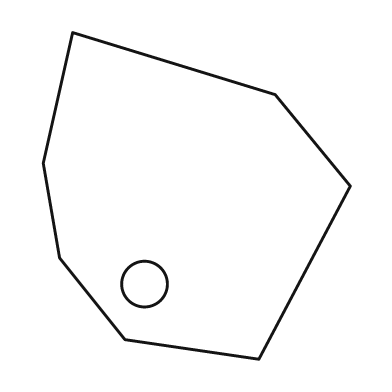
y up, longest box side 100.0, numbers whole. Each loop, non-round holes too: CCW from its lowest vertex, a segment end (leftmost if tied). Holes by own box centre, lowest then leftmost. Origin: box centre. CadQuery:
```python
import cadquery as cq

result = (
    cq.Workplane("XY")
    .moveTo(19.0, -50.0)
    .lineTo(47.0, 3.0)
    .lineTo(24.0, 31.0)
    .lineTo(-38.0, 50.0)
    .lineTo(-47.0, 10.0)
    .lineTo(-42.0, -19.0)
    .lineTo(-22.0, -44.0)
    .close()
    .moveTo(-16.0, -27.0)
    .circle(7.0)
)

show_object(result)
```